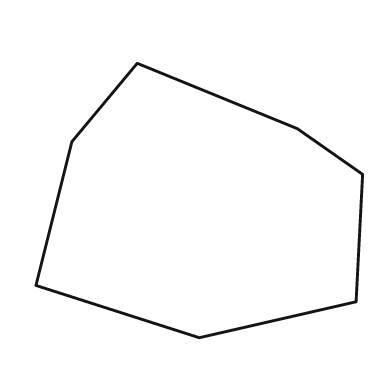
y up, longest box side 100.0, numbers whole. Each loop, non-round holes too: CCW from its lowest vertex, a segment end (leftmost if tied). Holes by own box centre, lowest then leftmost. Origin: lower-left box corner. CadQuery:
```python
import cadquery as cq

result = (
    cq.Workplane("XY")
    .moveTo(50.0, 0.0)
    .lineTo(98.0, 11.0)
    .lineTo(100.0, 50.0)
    .lineTo(80.0, 64.0)
    .lineTo(31.0, 84.0)
    .lineTo(11.0, 60.0)
    .lineTo(0.0, 16.0)
    .close()
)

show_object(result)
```